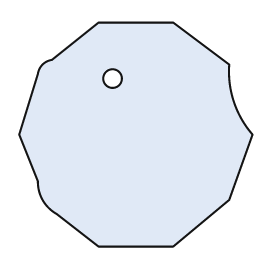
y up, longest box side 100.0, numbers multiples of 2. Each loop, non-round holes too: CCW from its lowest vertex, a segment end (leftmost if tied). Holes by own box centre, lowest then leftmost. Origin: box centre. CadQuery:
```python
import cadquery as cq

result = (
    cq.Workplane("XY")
    .moveTo(-16.0, -48.0)
    .lineTo(16.0, -48.0)
    .lineTo(40.0, -28.0)
    .lineTo(50.0, 0.0)
    .threePointArc((42.0, 14.0), (40.0, 30.0))
    .lineTo(16.0, 48.0)
    .lineTo(-16.0, 48.0)
    .lineTo(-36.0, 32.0)
    .threePointArc((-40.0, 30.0), (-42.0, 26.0))
    .lineTo(-50.0, 0.0)
    .lineTo(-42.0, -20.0)
    .threePointArc((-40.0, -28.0), (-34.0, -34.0))
    .close()
    .moveTo(-10.0, 24.0)
    .circle(4.0)
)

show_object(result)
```